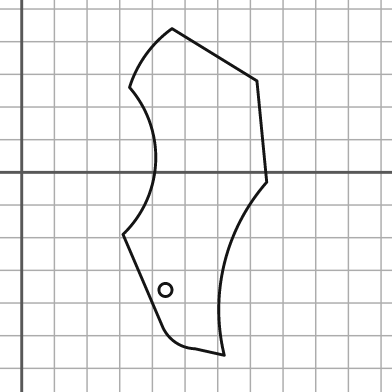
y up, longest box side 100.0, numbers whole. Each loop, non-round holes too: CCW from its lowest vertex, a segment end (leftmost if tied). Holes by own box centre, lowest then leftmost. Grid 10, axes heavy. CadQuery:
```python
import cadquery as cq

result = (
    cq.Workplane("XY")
    .moveTo(62.0, -56.0)
    .threePointArc((62.0, -28.0), (75.0, -3.0))
    .lineTo(72.0, 28.0)
    .lineTo(46.0, 44.0)
    .threePointArc((38.0, 36.0), (33.0, 26.0))
    .threePointArc((41.0, 3.0), (31.0, -19.0))
    .lineTo(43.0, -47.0)
    .threePointArc((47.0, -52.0), (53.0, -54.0))
    .close()
    .moveTo(44.0, -36.0)
    .circle(2.0)
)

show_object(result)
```